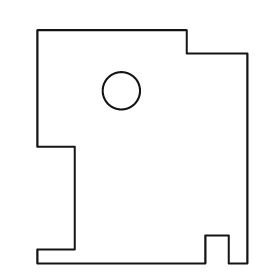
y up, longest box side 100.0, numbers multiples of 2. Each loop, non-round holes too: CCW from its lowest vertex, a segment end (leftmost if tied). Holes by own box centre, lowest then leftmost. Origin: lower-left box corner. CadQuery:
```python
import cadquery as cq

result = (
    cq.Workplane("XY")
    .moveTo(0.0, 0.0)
    .lineTo(72.0, 0.0)
    .lineTo(72.0, 12.0)
    .lineTo(82.0, 12.0)
    .lineTo(82.0, 0.0)
    .lineTo(90.0, 0.0)
    .lineTo(90.0, 90.0)
    .lineTo(64.0, 90.0)
    .lineTo(64.0, 100.0)
    .lineTo(0.0, 100.0)
    .lineTo(0.0, 50.0)
    .lineTo(16.0, 50.0)
    .lineTo(16.0, 6.0)
    .lineTo(0.0, 6.0)
    .close()
    .moveTo(36.0, 74.0)
    .circle(8.0)
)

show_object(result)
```